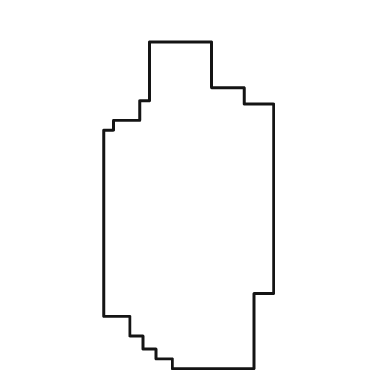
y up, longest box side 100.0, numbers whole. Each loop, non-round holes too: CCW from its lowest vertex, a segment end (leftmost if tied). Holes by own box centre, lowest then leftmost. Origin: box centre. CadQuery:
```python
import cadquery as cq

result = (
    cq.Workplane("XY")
    .moveTo(-5.0, -50.0)
    .lineTo(20.0, -50.0)
    .lineTo(20.0, -27.0)
    .lineTo(26.0, -27.0)
    .lineTo(26.0, 31.0)
    .lineTo(17.0, 31.0)
    .lineTo(17.0, 36.0)
    .lineTo(7.0, 36.0)
    .lineTo(7.0, 50.0)
    .lineTo(-12.0, 50.0)
    .lineTo(-12.0, 32.0)
    .lineTo(-15.0, 32.0)
    .lineTo(-15.0, 26.0)
    .lineTo(-23.0, 26.0)
    .lineTo(-23.0, 23.0)
    .lineTo(-26.0, 23.0)
    .lineTo(-26.0, -34.0)
    .lineTo(-18.0, -34.0)
    .lineTo(-18.0, -40.0)
    .lineTo(-14.0, -40.0)
    .lineTo(-14.0, -44.0)
    .lineTo(-10.0, -44.0)
    .lineTo(-10.0, -47.0)
    .lineTo(-5.0, -47.0)
    .close()
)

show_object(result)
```